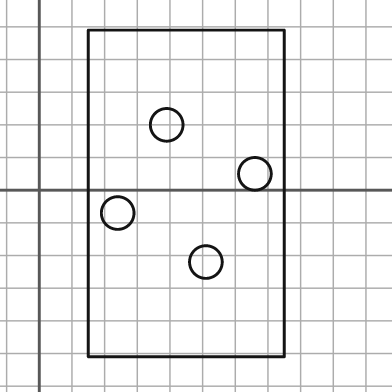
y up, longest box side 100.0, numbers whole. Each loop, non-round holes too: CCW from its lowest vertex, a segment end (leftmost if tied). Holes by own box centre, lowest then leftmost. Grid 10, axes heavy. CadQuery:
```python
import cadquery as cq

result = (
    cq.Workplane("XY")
    .moveTo(15.0, -51.0)
    .lineTo(75.0, -51.0)
    .lineTo(75.0, 49.0)
    .lineTo(15.0, 49.0)
    .close()
    .moveTo(51.0, -22.0)
    .circle(5.0)
    .moveTo(24.0, -7.0)
    .circle(5.0)
    .moveTo(66.0, 5.0)
    .circle(5.0)
    .moveTo(39.0, 20.0)
    .circle(5.0)
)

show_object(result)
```